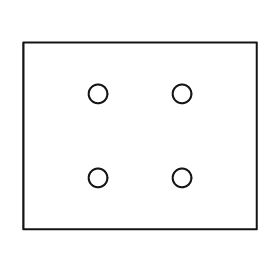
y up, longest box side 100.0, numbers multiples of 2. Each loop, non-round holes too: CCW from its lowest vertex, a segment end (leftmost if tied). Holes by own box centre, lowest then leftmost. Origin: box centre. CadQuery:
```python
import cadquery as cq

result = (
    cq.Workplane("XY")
    .moveTo(-50.0, -40.0)
    .lineTo(50.0, -40.0)
    .lineTo(50.0, 40.0)
    .lineTo(-50.0, 40.0)
    .close()
    .moveTo(-18.0, -18.0)
    .circle(4.0)
    .moveTo(18.0, -18.0)
    .circle(4.0)
    .moveTo(-18.0, 18.0)
    .circle(4.0)
    .moveTo(18.0, 18.0)
    .circle(4.0)
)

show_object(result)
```